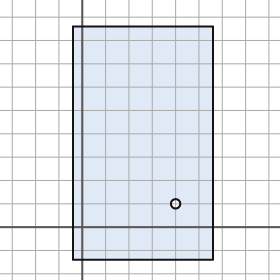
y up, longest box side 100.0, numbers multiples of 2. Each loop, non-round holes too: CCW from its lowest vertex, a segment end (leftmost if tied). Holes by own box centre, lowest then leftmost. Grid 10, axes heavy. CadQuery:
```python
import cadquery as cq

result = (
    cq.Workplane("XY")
    .moveTo(-4.0, -14.0)
    .lineTo(56.0, -14.0)
    .lineTo(56.0, 86.0)
    .lineTo(-4.0, 86.0)
    .close()
    .moveTo(40.0, 10.0)
    .circle(2.0)
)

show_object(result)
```